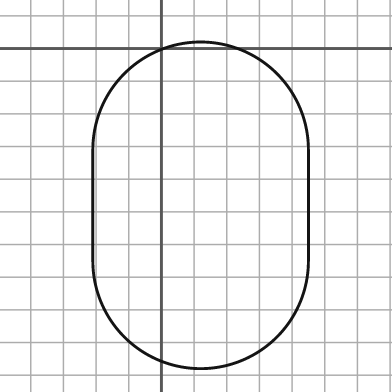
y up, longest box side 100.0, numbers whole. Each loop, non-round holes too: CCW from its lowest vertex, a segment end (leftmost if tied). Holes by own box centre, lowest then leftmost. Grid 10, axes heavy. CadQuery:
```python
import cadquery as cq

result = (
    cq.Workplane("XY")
    .moveTo(-21.0, -65.0)
    .threePointArc((12.0, -98.0), (45.0, -65.0))
    .lineTo(45.0, -31.0)
    .threePointArc((12.0, 2.0), (-21.0, -31.0))
    .close()
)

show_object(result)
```